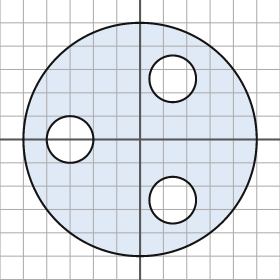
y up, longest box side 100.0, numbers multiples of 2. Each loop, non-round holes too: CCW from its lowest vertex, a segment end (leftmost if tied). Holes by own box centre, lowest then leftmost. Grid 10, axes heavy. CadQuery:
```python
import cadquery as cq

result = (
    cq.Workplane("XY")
    .moveTo(0.0, 0.0)
    .circle(50.0)
    .moveTo(14.0, -26.0)
    .circle(10.0)
    .moveTo(-30.0, 0.0)
    .circle(10.0)
    .moveTo(14.0, 26.0)
    .circle(10.0)
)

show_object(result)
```